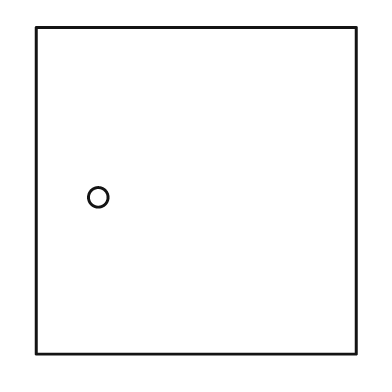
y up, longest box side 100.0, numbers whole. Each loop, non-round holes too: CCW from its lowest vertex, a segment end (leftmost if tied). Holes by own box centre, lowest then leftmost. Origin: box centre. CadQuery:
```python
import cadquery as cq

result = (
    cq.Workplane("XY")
    .moveTo(-49.0, -50.0)
    .lineTo(49.0, -50.0)
    .lineTo(49.0, 50.0)
    .lineTo(-49.0, 50.0)
    .close()
    .moveTo(-30.0, -2.0)
    .circle(3.0)
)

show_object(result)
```